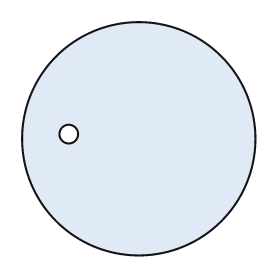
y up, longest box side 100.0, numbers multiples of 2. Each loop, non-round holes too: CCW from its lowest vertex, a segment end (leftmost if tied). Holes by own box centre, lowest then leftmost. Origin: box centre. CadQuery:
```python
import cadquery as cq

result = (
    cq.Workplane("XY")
    .moveTo(0.0, 0.0)
    .circle(50.0)
    .moveTo(-30.0, 2.0)
    .circle(4.0)
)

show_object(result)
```